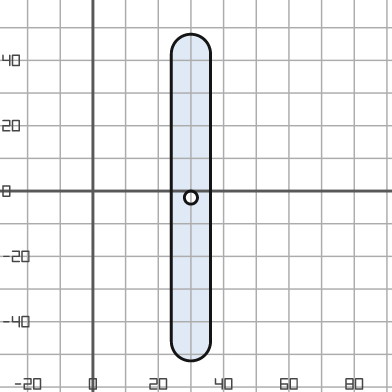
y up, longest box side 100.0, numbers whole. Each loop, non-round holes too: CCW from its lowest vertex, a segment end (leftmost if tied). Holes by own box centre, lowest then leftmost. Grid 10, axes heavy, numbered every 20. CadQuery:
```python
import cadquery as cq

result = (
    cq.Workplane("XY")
    .moveTo(24.0, -46.0)
    .threePointArc((30.0, -52.0), (36.0, -46.0))
    .lineTo(36.0, 42.0)
    .threePointArc((30.0, 48.0), (24.0, 42.0))
    .close()
    .moveTo(30.0, -2.0)
    .circle(2.0)
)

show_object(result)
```